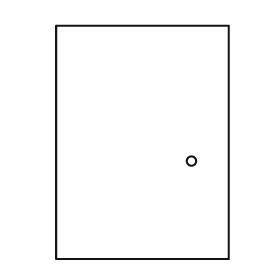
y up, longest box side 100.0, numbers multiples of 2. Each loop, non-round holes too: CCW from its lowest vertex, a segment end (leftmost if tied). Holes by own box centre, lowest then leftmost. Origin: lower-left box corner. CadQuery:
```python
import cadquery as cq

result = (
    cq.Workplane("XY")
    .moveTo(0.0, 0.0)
    .lineTo(74.0, 0.0)
    .lineTo(74.0, 100.0)
    .lineTo(0.0, 100.0)
    .close()
    .moveTo(58.0, 42.0)
    .circle(2.0)
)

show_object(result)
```